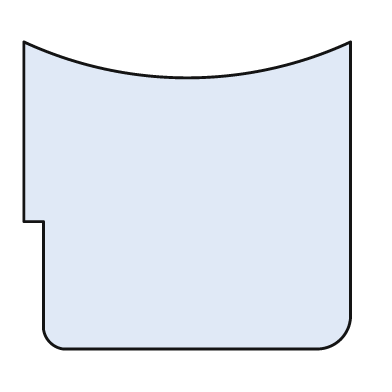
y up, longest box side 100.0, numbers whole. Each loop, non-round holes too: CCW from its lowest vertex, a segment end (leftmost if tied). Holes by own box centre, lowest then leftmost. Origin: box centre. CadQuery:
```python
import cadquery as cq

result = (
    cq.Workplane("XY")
    .moveTo(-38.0, -47.0)
    .lineTo(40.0, -47.0)
    .threePointArc((47.0, -44.0), (50.0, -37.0))
    .lineTo(50.0, 47.0)
    .threePointArc((0.0, 36.0), (-50.0, 47.0))
    .lineTo(-50.0, -8.0)
    .lineTo(-44.0, -8.0)
    .lineTo(-44.0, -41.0)
    .threePointArc((-42.0, -45.0), (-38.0, -47.0))
    .close()
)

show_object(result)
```